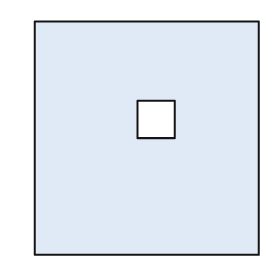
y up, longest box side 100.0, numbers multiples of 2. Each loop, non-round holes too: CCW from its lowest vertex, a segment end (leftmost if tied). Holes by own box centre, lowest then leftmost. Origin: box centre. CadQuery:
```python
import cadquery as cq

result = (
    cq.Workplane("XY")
    .moveTo(-48.0, -50.0)
    .lineTo(48.0, -50.0)
    .lineTo(48.0, 50.0)
    .lineTo(-48.0, 50.0)
    .close()
    .moveTo(-4.0, 0.0)
    .lineTo(12.0, 0.0)
    .lineTo(12.0, 16.0)
    .lineTo(-4.0, 16.0)
    .close()
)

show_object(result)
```